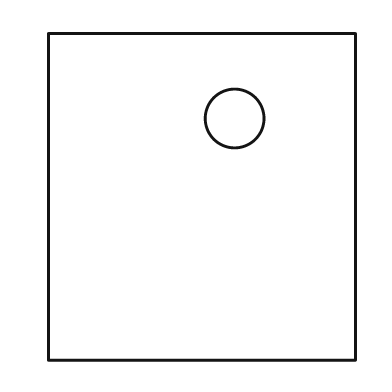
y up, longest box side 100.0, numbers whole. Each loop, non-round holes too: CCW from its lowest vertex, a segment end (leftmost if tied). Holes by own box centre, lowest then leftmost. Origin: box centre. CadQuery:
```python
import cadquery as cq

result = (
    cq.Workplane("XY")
    .moveTo(-47.0, -50.0)
    .lineTo(47.0, -50.0)
    .lineTo(47.0, 50.0)
    .lineTo(-47.0, 50.0)
    .close()
    .moveTo(10.0, 24.0)
    .circle(9.0)
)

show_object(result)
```